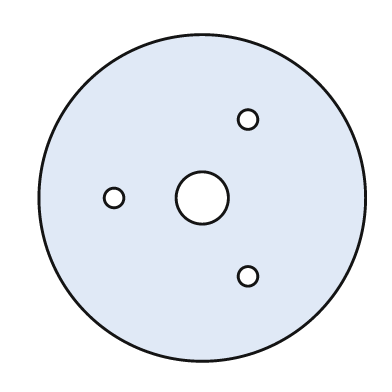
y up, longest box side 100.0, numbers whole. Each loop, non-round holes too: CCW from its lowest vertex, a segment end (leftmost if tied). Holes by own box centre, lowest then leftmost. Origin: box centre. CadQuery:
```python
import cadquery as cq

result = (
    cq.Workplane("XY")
    .moveTo(0.0, 0.0)
    .circle(50.0)
    .moveTo(14.0, -24.0)
    .circle(3.0)
    .moveTo(-27.0, 0.0)
    .circle(3.0)
    .moveTo(0.0, 0.0)
    .circle(8.0)
    .moveTo(14.0, 24.0)
    .circle(3.0)
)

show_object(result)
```